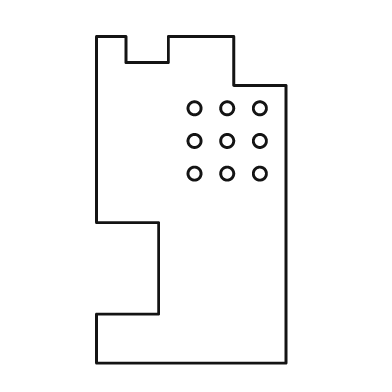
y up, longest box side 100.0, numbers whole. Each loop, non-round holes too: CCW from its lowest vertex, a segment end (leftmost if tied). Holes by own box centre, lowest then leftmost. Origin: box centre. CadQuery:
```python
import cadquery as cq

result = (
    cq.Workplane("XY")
    .moveTo(-29.0, -50.0)
    .lineTo(29.0, -50.0)
    .lineTo(29.0, 35.0)
    .lineTo(13.0, 35.0)
    .lineTo(13.0, 50.0)
    .lineTo(-7.0, 50.0)
    .lineTo(-7.0, 42.0)
    .lineTo(-20.0, 42.0)
    .lineTo(-20.0, 50.0)
    .lineTo(-29.0, 50.0)
    .lineTo(-29.0, -7.0)
    .lineTo(-10.0, -7.0)
    .lineTo(-10.0, -35.0)
    .lineTo(-29.0, -35.0)
    .close()
    .moveTo(1.0, 8.0)
    .circle(2.0)
    .moveTo(11.0, 8.0)
    .circle(2.0)
    .moveTo(21.0, 8.0)
    .circle(2.0)
    .moveTo(1.0, 18.0)
    .circle(2.0)
    .moveTo(11.0, 18.0)
    .circle(2.0)
    .moveTo(21.0, 18.0)
    .circle(2.0)
    .moveTo(1.0, 28.0)
    .circle(2.0)
    .moveTo(11.0, 28.0)
    .circle(2.0)
    .moveTo(21.0, 28.0)
    .circle(2.0)
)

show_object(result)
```